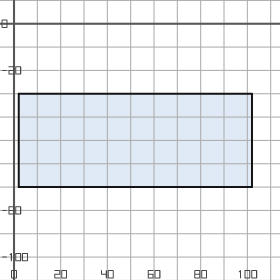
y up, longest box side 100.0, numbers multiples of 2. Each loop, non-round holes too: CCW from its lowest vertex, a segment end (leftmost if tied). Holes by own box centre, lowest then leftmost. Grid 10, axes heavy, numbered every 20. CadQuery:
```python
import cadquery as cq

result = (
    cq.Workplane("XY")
    .moveTo(2.0, -70.0)
    .lineTo(102.0, -70.0)
    .lineTo(102.0, -30.0)
    .lineTo(2.0, -30.0)
    .close()
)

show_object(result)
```